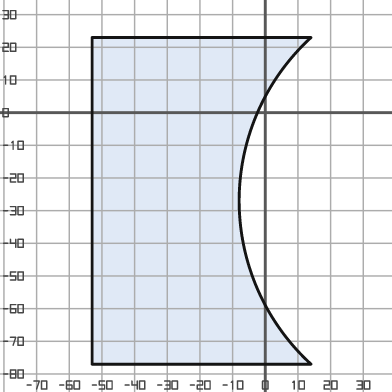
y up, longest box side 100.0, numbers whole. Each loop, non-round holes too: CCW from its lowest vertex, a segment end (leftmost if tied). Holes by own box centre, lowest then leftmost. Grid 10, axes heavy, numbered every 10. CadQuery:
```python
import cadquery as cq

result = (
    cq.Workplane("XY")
    .moveTo(-53.0, -77.0)
    .lineTo(14.0, -77.0)
    .threePointArc((-8.0, -27.0), (14.0, 23.0))
    .lineTo(-53.0, 23.0)
    .close()
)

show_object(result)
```